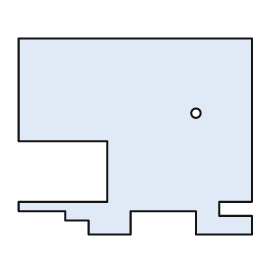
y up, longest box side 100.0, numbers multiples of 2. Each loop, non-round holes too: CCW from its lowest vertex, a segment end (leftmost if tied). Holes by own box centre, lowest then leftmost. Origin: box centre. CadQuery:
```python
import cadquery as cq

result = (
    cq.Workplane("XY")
    .moveTo(-20.0, -42.0)
    .lineTo(-2.0, -42.0)
    .lineTo(-2.0, -32.0)
    .lineTo(26.0, -32.0)
    .lineTo(26.0, -42.0)
    .lineTo(50.0, -42.0)
    .lineTo(50.0, -34.0)
    .lineTo(36.0, -34.0)
    .lineTo(36.0, -28.0)
    .lineTo(50.0, -28.0)
    .lineTo(50.0, 42.0)
    .lineTo(-50.0, 42.0)
    .lineTo(-50.0, -2.0)
    .lineTo(-12.0, -2.0)
    .lineTo(-12.0, -28.0)
    .lineTo(-50.0, -28.0)
    .lineTo(-50.0, -32.0)
    .lineTo(-30.0, -32.0)
    .lineTo(-30.0, -36.0)
    .lineTo(-20.0, -36.0)
    .close()
    .moveTo(26.0, 10.0)
    .circle(2.0)
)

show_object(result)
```